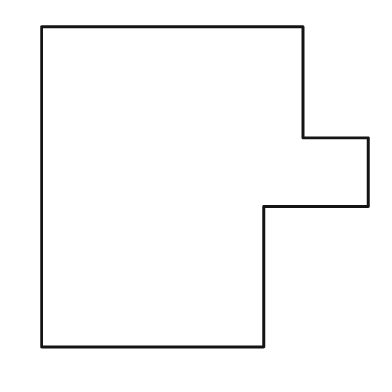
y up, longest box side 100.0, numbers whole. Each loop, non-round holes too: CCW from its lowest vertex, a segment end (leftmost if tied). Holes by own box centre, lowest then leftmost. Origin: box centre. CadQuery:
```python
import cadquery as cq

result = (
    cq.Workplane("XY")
    .moveTo(-50.0, -49.0)
    .lineTo(18.0, -49.0)
    .lineTo(18.0, -6.0)
    .lineTo(50.0, -6.0)
    .lineTo(50.0, 15.0)
    .lineTo(30.0, 15.0)
    .lineTo(30.0, 49.0)
    .lineTo(-50.0, 49.0)
    .close()
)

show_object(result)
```